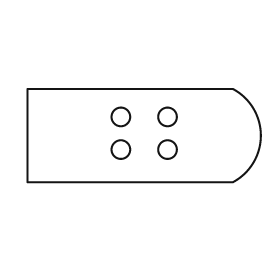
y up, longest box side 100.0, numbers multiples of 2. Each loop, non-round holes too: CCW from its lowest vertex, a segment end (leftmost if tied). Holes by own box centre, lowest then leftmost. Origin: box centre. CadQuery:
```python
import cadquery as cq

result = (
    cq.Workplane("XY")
    .moveTo(-50.0, -20.0)
    .lineTo(38.0, -20.0)
    .threePointArc((50.0, 0.0), (38.0, 20.0))
    .lineTo(-50.0, 20.0)
    .close()
    .moveTo(-10.0, -6.0)
    .circle(4.0)
    .moveTo(10.0, -6.0)
    .circle(4.0)
    .moveTo(-10.0, 8.0)
    .circle(4.0)
    .moveTo(10.0, 8.0)
    .circle(4.0)
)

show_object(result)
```